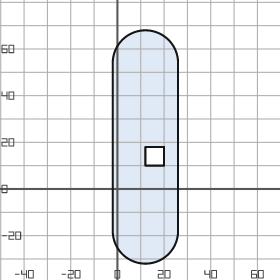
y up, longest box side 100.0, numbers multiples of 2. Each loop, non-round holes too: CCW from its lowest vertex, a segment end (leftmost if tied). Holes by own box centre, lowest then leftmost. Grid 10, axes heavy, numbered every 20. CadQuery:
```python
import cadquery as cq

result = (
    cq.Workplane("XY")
    .moveTo(-2.0, -18.0)
    .threePointArc((12.0, -32.0), (26.0, -18.0))
    .lineTo(26.0, 54.0)
    .threePointArc((12.0, 68.0), (-2.0, 54.0))
    .close()
    .moveTo(12.0, 10.0)
    .lineTo(20.0, 10.0)
    .lineTo(20.0, 18.0)
    .lineTo(12.0, 18.0)
    .close()
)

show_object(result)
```